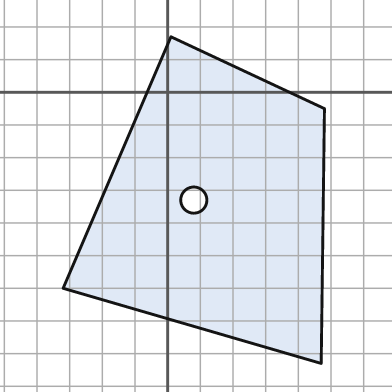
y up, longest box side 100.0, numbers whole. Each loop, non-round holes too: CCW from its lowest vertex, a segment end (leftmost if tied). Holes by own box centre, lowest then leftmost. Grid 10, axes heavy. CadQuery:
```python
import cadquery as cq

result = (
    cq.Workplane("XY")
    .moveTo(47.0, -83.0)
    .lineTo(48.0, -5.0)
    .lineTo(1.0, 17.0)
    .lineTo(-32.0, -60.0)
    .close()
    .moveTo(8.0, -33.0)
    .circle(4.0)
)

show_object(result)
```